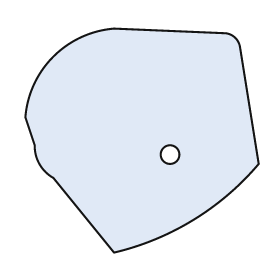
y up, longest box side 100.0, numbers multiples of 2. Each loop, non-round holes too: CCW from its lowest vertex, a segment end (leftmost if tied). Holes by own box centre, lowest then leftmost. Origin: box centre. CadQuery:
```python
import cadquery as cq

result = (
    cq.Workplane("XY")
    .moveTo(-12.0, -48.0)
    .threePointArc((22.0, -34.0), (50.0, -10.0))
    .lineTo(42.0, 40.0)
    .threePointArc((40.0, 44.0), (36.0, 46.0))
    .lineTo(-12.0, 48.0)
    .threePointArc((-38.0, 36.0), (-50.0, 10.0))
    .lineTo(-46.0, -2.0)
    .threePointArc((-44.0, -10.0), (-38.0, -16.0))
    .close()
    .moveTo(12.0, -6.0)
    .circle(4.0)
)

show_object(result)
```